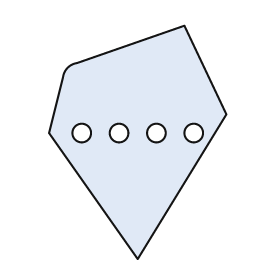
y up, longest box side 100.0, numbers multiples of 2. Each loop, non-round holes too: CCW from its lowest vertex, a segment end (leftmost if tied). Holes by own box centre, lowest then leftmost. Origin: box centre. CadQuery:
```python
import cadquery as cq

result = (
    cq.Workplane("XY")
    .moveTo(0.0, -50.0)
    .lineTo(38.0, 12.0)
    .lineTo(20.0, 50.0)
    .lineTo(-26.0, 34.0)
    .threePointArc((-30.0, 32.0), (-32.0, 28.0))
    .lineTo(-38.0, 4.0)
    .close()
    .moveTo(-24.0, 4.0)
    .circle(4.0)
    .moveTo(-8.0, 4.0)
    .circle(4.0)
    .moveTo(8.0, 4.0)
    .circle(4.0)
    .moveTo(24.0, 4.0)
    .circle(4.0)
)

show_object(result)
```